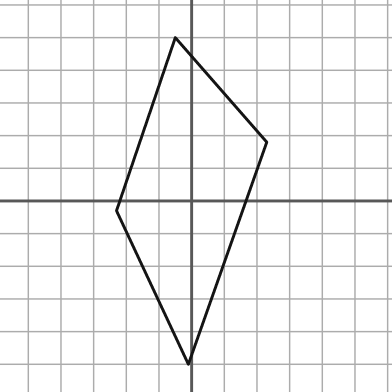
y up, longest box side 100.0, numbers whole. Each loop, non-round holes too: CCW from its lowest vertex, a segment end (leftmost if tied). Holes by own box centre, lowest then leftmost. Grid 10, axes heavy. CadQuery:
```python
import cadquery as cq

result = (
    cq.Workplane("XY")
    .moveTo(-1.0, -50.0)
    .lineTo(23.0, 18.0)
    .lineTo(-5.0, 50.0)
    .lineTo(-23.0, -3.0)
    .close()
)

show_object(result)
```